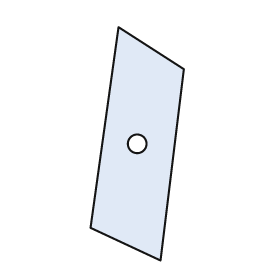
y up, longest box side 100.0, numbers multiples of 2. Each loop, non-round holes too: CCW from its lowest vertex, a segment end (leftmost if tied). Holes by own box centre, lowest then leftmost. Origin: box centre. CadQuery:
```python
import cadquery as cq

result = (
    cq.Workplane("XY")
    .moveTo(10.0, -50.0)
    .lineTo(20.0, 32.0)
    .lineTo(-8.0, 50.0)
    .lineTo(-20.0, -36.0)
    .close()
    .moveTo(0.0, 0.0)
    .circle(4.0)
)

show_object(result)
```